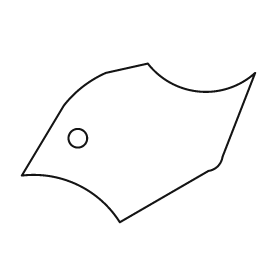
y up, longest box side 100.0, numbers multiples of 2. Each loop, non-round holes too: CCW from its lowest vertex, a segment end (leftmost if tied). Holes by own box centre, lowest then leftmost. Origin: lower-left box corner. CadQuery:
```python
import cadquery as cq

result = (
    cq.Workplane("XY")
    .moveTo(42.0, 0.0)
    .lineTo(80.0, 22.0)
    .threePointArc((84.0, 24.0), (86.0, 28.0))
    .lineTo(100.0, 64.0)
    .threePointArc((76.0, 56.0), (54.0, 68.0))
    .lineTo(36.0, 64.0)
    .threePointArc((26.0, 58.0), (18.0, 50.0))
    .lineTo(0.0, 20.0)
    .threePointArc((24.0, 16.0), (42.0, 0.0))
    .close()
    .moveTo(24.0, 36.0)
    .circle(4.0)
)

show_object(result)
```